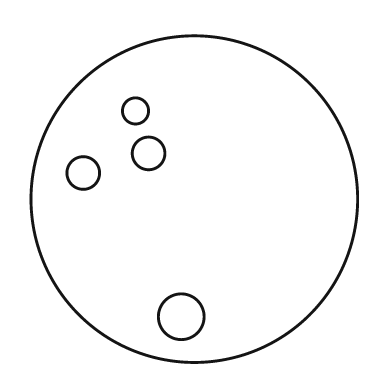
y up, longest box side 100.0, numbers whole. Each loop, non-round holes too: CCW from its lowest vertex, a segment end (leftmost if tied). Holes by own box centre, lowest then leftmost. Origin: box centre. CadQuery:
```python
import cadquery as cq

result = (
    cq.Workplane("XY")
    .moveTo(0.0, 0.0)
    .circle(50.0)
    .moveTo(-4.0, -36.0)
    .circle(7.0)
    .moveTo(-34.0, 8.0)
    .circle(5.0)
    .moveTo(-14.0, 14.0)
    .circle(5.0)
    .moveTo(-18.0, 27.0)
    .circle(4.0)
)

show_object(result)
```